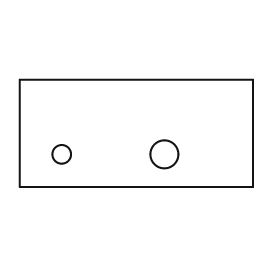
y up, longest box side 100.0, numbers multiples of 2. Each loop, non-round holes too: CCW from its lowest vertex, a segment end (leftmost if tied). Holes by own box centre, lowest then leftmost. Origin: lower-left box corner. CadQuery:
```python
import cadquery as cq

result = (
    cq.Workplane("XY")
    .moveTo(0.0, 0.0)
    .lineTo(100.0, 0.0)
    .lineTo(100.0, 46.0)
    .lineTo(0.0, 46.0)
    .close()
    .moveTo(18.0, 14.0)
    .circle(4.0)
    .moveTo(62.0, 14.0)
    .circle(6.0)
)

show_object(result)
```